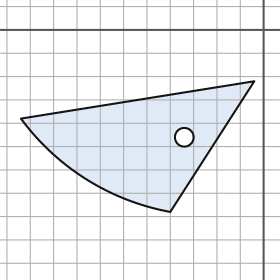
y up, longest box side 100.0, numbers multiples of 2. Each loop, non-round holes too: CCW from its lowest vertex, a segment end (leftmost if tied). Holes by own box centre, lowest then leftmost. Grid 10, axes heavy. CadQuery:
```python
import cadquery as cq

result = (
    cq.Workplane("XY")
    .moveTo(-40.0, -78.0)
    .lineTo(-4.0, -22.0)
    .lineTo(-104.0, -38.0)
    .threePointArc((-76.0, -64.0), (-40.0, -78.0))
    .close()
    .moveTo(-34.0, -46.0)
    .circle(4.0)
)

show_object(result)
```